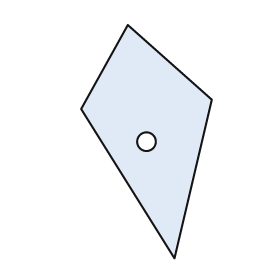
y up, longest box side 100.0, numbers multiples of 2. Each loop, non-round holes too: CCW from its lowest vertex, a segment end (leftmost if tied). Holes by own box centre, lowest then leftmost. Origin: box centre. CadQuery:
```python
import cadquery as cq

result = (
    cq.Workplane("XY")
    .moveTo(12.0, -50.0)
    .lineTo(28.0, 18.0)
    .lineTo(-8.0, 50.0)
    .lineTo(-28.0, 14.0)
    .close()
    .moveTo(0.0, 0.0)
    .circle(4.0)
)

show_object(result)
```